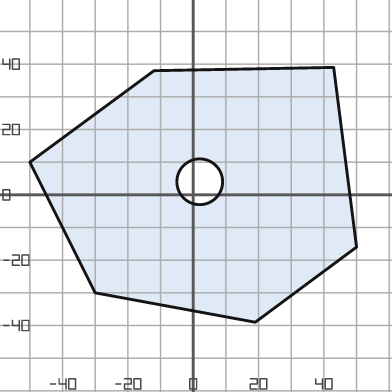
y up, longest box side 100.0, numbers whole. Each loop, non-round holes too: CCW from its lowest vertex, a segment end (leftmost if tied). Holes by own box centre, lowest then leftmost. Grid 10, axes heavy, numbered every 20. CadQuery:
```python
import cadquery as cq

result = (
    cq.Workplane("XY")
    .moveTo(19.0, -39.0)
    .lineTo(50.0, -16.0)
    .lineTo(43.0, 39.0)
    .lineTo(-12.0, 38.0)
    .lineTo(-50.0, 10.0)
    .lineTo(-30.0, -30.0)
    .close()
    .moveTo(2.0, 4.0)
    .circle(7.0)
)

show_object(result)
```